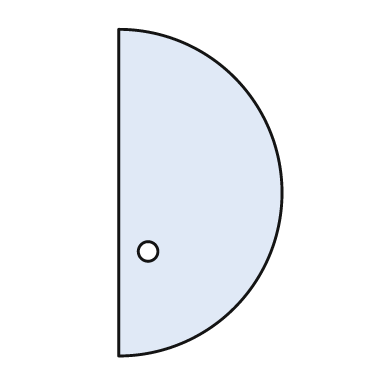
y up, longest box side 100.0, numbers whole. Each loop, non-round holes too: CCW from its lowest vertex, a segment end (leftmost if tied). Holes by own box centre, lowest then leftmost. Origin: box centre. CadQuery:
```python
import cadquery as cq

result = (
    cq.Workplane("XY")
    .moveTo(-25.0, -50.0)
    .threePointArc((25.0, 0.0), (-25.0, 50.0))
    .close()
    .moveTo(-16.0, -18.0)
    .circle(3.0)
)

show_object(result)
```